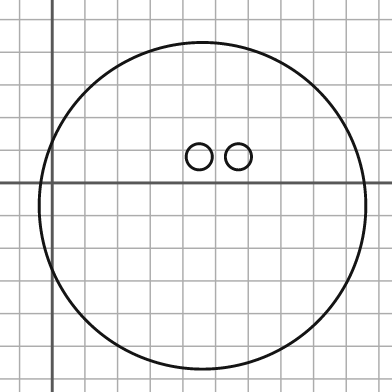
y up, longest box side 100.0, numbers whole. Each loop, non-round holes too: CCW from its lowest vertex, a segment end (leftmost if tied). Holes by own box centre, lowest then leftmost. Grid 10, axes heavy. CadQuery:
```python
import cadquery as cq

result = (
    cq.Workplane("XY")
    .moveTo(46.0, -7.0)
    .circle(50.0)
    .moveTo(45.0, 8.0)
    .circle(4.0)
    .moveTo(57.0, 8.0)
    .circle(4.0)
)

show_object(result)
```